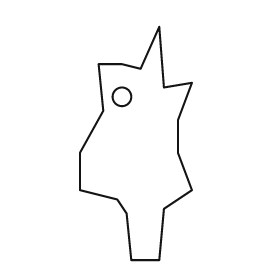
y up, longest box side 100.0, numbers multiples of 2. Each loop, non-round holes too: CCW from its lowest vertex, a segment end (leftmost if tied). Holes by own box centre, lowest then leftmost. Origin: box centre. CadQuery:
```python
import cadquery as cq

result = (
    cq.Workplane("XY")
    .moveTo(-2.0, -50.0)
    .lineTo(10.0, -50.0)
    .lineTo(12.0, -28.0)
    .lineTo(24.0, -20.0)
    .lineTo(18.0, -4.0)
    .lineTo(18.0, 10.0)
    .lineTo(24.0, 26.0)
    .lineTo(12.0, 24.0)
    .lineTo(10.0, 50.0)
    .lineTo(2.0, 32.0)
    .lineTo(-6.0, 34.0)
    .lineTo(-16.0, 34.0)
    .lineTo(-14.0, 14.0)
    .lineTo(-24.0, -4.0)
    .lineTo(-24.0, -20.0)
    .lineTo(-8.0, -24.0)
    .lineTo(-4.0, -30.0)
    .close()
    .moveTo(-6.0, 20.0)
    .circle(4.0)
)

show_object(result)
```